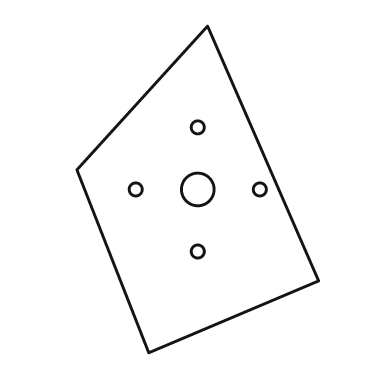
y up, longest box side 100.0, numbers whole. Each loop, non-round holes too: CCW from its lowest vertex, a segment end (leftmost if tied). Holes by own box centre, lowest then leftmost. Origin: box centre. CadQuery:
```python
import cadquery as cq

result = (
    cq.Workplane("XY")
    .moveTo(-15.0, -50.0)
    .lineTo(37.0, -28.0)
    .lineTo(3.0, 50.0)
    .lineTo(-37.0, 6.0)
    .close()
    .moveTo(0.0, -19.0)
    .circle(2.0)
    .moveTo(-19.0, 0.0)
    .circle(2.0)
    .moveTo(0.0, 0.0)
    .circle(5.0)
    .moveTo(19.0, 0.0)
    .circle(2.0)
    .moveTo(0.0, 19.0)
    .circle(2.0)
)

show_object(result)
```